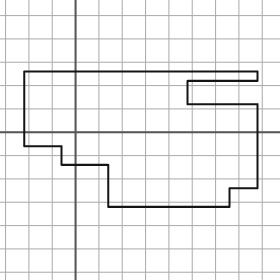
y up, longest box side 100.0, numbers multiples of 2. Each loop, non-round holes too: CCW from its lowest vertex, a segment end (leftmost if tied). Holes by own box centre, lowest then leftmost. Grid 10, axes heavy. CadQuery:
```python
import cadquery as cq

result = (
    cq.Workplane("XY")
    .moveTo(14.0, -32.0)
    .lineTo(66.0, -32.0)
    .lineTo(66.0, -24.0)
    .lineTo(78.0, -24.0)
    .lineTo(78.0, 12.0)
    .lineTo(48.0, 12.0)
    .lineTo(48.0, 22.0)
    .lineTo(78.0, 22.0)
    .lineTo(78.0, 26.0)
    .lineTo(-22.0, 26.0)
    .lineTo(-22.0, -6.0)
    .lineTo(-6.0, -6.0)
    .lineTo(-6.0, -14.0)
    .lineTo(14.0, -14.0)
    .close()
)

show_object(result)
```